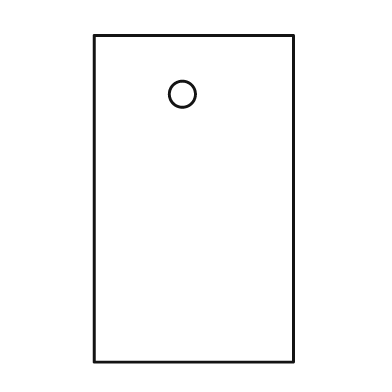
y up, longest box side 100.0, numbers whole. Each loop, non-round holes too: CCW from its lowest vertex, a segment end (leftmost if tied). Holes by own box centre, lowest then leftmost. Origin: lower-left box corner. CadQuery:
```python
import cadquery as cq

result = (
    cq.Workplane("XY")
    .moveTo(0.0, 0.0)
    .lineTo(61.0, 0.0)
    .lineTo(61.0, 100.0)
    .lineTo(0.0, 100.0)
    .close()
    .moveTo(27.0, 82.0)
    .circle(4.0)
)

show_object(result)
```